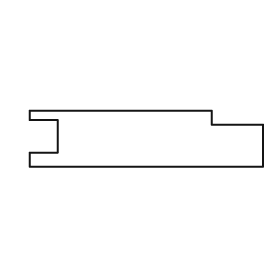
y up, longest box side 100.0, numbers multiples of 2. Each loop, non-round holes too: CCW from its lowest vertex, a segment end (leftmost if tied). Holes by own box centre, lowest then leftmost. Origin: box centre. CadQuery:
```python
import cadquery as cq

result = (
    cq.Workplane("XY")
    .moveTo(-50.0, -12.0)
    .lineTo(50.0, -12.0)
    .lineTo(50.0, 6.0)
    .lineTo(28.0, 6.0)
    .lineTo(28.0, 12.0)
    .lineTo(-50.0, 12.0)
    .lineTo(-50.0, 8.0)
    .lineTo(-38.0, 8.0)
    .lineTo(-38.0, -6.0)
    .lineTo(-50.0, -6.0)
    .close()
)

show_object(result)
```